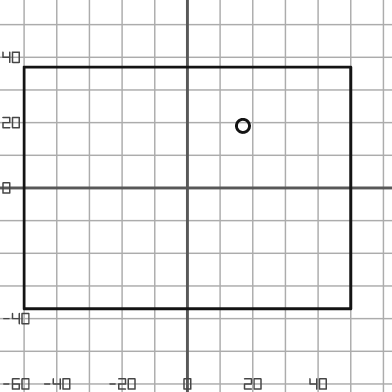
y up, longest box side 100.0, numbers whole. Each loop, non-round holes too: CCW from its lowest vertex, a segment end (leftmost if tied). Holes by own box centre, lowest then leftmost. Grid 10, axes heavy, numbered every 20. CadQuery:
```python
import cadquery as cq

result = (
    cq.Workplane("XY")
    .moveTo(-50.0, -37.0)
    .lineTo(50.0, -37.0)
    .lineTo(50.0, 37.0)
    .lineTo(-50.0, 37.0)
    .close()
    .moveTo(17.0, 19.0)
    .circle(2.0)
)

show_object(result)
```